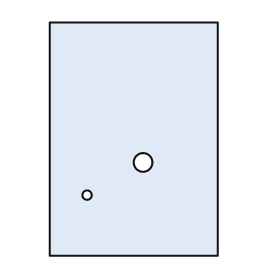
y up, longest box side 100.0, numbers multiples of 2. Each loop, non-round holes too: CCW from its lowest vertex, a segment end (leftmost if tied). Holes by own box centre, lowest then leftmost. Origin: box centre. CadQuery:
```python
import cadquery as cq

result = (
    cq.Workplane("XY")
    .moveTo(-36.0, -50.0)
    .lineTo(36.0, -50.0)
    .lineTo(36.0, 50.0)
    .lineTo(-36.0, 50.0)
    .close()
    .moveTo(-20.0, -24.0)
    .circle(2.0)
    .moveTo(4.0, -10.0)
    .circle(4.0)
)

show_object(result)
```